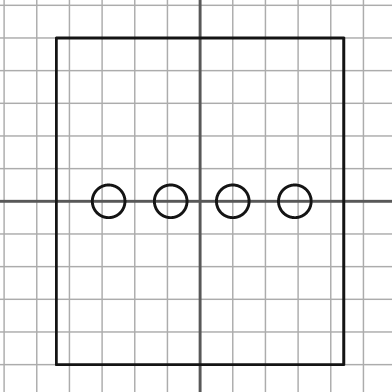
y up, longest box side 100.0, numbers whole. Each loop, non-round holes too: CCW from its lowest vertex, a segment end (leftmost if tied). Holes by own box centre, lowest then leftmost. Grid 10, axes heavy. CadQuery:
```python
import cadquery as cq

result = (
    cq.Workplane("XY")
    .moveTo(-44.0, -50.0)
    .lineTo(44.0, -50.0)
    .lineTo(44.0, 50.0)
    .lineTo(-44.0, 50.0)
    .close()
    .moveTo(-28.0, 0.0)
    .circle(5.0)
    .moveTo(-9.0, 0.0)
    .circle(5.0)
    .moveTo(10.0, 0.0)
    .circle(5.0)
    .moveTo(29.0, 0.0)
    .circle(5.0)
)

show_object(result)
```